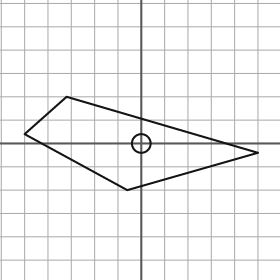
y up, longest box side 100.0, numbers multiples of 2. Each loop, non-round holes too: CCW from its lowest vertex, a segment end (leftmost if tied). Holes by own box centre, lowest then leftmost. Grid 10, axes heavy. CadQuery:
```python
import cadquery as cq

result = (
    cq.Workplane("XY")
    .moveTo(-6.0, -20.0)
    .lineTo(50.0, -4.0)
    .lineTo(-32.0, 20.0)
    .lineTo(-50.0, 4.0)
    .close()
    .moveTo(0.0, 0.0)
    .circle(4.0)
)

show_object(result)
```